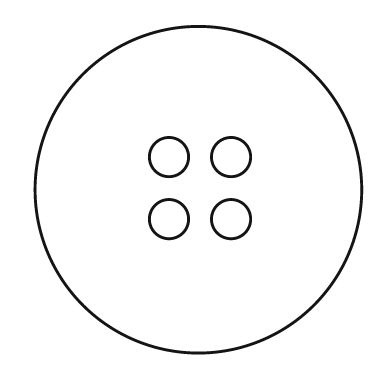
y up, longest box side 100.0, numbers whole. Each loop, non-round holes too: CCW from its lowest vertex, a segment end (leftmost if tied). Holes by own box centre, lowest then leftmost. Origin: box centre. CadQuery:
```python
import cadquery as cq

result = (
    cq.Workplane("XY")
    .moveTo(0.0, 0.0)
    .circle(50.0)
    .moveTo(-9.0, -9.0)
    .circle(6.0)
    .moveTo(10.0, -9.0)
    .circle(6.0)
    .moveTo(-9.0, 10.0)
    .circle(6.0)
    .moveTo(10.0, 10.0)
    .circle(6.0)
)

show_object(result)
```